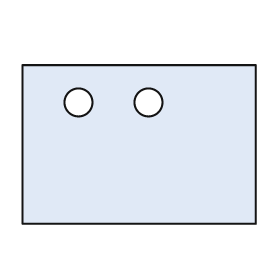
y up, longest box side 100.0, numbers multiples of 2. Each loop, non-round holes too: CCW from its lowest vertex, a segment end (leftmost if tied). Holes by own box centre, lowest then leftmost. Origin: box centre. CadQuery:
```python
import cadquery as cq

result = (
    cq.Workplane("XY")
    .moveTo(-50.0, -34.0)
    .lineTo(50.0, -34.0)
    .lineTo(50.0, 34.0)
    .lineTo(-50.0, 34.0)
    .close()
    .moveTo(-26.0, 18.0)
    .circle(6.0)
    .moveTo(4.0, 18.0)
    .circle(6.0)
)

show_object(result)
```